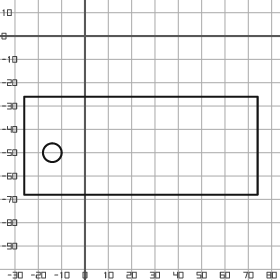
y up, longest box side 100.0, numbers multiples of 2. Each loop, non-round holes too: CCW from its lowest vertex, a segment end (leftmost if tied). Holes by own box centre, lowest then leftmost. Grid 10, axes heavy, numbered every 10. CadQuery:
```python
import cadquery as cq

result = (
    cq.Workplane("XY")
    .moveTo(-26.0, -68.0)
    .lineTo(74.0, -68.0)
    .lineTo(74.0, -26.0)
    .lineTo(-26.0, -26.0)
    .close()
    .moveTo(-14.0, -50.0)
    .circle(4.0)
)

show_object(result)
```